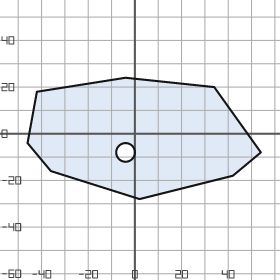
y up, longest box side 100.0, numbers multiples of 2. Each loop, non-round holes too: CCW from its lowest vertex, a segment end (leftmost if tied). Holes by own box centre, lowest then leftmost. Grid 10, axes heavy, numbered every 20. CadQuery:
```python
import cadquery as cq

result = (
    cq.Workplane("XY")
    .moveTo(2.0, -28.0)
    .lineTo(42.0, -18.0)
    .lineTo(54.0, -8.0)
    .lineTo(34.0, 20.0)
    .lineTo(-4.0, 24.0)
    .lineTo(-42.0, 18.0)
    .lineTo(-46.0, -4.0)
    .lineTo(-36.0, -16.0)
    .close()
    .moveTo(-4.0, -8.0)
    .circle(4.0)
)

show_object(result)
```